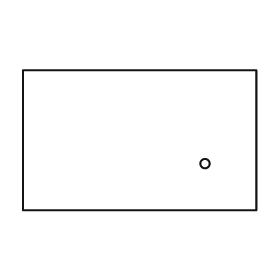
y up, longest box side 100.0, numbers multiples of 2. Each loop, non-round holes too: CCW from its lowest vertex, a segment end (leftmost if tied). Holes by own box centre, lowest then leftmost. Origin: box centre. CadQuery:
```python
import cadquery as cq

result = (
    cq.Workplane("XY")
    .moveTo(-50.0, -30.0)
    .lineTo(50.0, -30.0)
    .lineTo(50.0, 30.0)
    .lineTo(-50.0, 30.0)
    .close()
    .moveTo(28.0, -10.0)
    .circle(2.0)
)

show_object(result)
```